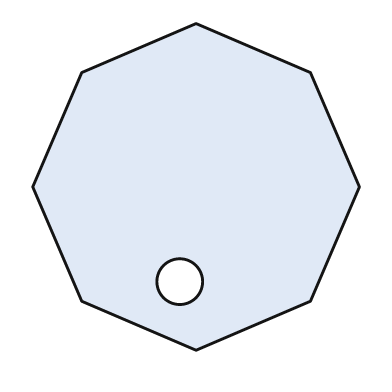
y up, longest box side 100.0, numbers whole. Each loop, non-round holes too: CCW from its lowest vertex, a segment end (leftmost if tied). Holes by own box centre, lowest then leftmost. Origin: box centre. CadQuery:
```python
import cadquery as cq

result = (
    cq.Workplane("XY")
    .moveTo(0.0, -50.0)
    .lineTo(35.0, -35.0)
    .lineTo(50.0, 0.0)
    .lineTo(35.0, 35.0)
    .lineTo(0.0, 50.0)
    .lineTo(-35.0, 35.0)
    .lineTo(-50.0, 0.0)
    .lineTo(-35.0, -35.0)
    .close()
    .moveTo(-5.0, -29.0)
    .circle(7.0)
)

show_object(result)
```